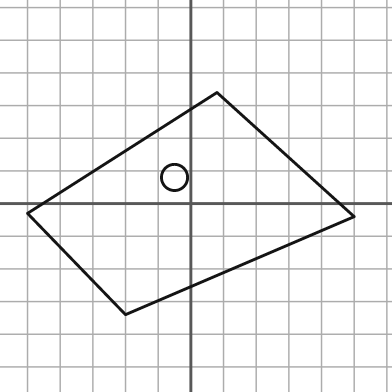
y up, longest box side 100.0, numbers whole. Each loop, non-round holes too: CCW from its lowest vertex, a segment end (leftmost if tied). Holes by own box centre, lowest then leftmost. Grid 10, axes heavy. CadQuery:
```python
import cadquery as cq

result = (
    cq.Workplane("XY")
    .moveTo(-20.0, -34.0)
    .lineTo(50.0, -4.0)
    .lineTo(8.0, 34.0)
    .lineTo(-50.0, -3.0)
    .close()
    .moveTo(-5.0, 8.0)
    .circle(4.0)
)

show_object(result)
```